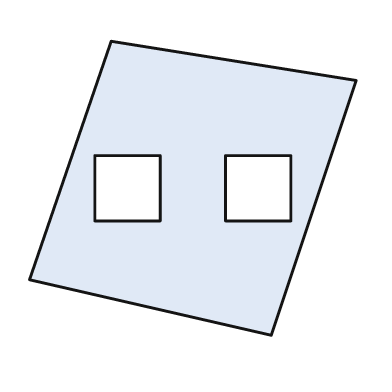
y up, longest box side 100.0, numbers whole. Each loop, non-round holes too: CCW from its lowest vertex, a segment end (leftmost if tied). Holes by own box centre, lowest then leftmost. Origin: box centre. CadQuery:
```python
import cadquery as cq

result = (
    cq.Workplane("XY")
    .moveTo(24.0, -45.0)
    .lineTo(50.0, 33.0)
    .lineTo(-25.0, 45.0)
    .lineTo(-50.0, -28.0)
    .close()
    .moveTo(-30.0, -10.0)
    .lineTo(-10.0, -10.0)
    .lineTo(-10.0, 10.0)
    .lineTo(-30.0, 10.0)
    .close()
    .moveTo(10.0, -10.0)
    .lineTo(30.0, -10.0)
    .lineTo(30.0, 10.0)
    .lineTo(10.0, 10.0)
    .close()
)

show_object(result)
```